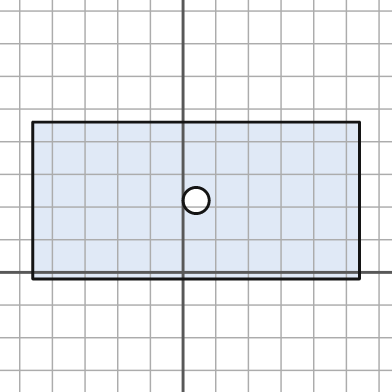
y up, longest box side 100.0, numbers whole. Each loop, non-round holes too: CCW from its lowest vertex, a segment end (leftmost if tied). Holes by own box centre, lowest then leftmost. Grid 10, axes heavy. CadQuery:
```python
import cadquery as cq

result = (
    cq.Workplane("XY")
    .moveTo(-46.0, -2.0)
    .lineTo(54.0, -2.0)
    .lineTo(54.0, 46.0)
    .lineTo(-46.0, 46.0)
    .close()
    .moveTo(4.0, 22.0)
    .circle(4.0)
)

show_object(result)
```